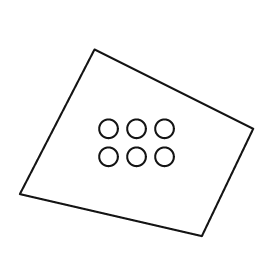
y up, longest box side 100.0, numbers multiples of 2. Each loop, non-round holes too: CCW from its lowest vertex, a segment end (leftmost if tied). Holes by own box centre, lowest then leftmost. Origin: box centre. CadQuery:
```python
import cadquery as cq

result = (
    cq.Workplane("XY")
    .moveTo(28.0, -40.0)
    .lineTo(50.0, 6.0)
    .lineTo(-18.0, 40.0)
    .lineTo(-50.0, -22.0)
    .close()
    .moveTo(-12.0, -6.0)
    .circle(4.0)
    .moveTo(0.0, -6.0)
    .circle(4.0)
    .moveTo(12.0, -6.0)
    .circle(4.0)
    .moveTo(-12.0, 6.0)
    .circle(4.0)
    .moveTo(0.0, 6.0)
    .circle(4.0)
    .moveTo(12.0, 6.0)
    .circle(4.0)
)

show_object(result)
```